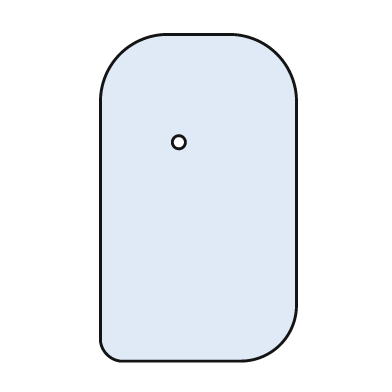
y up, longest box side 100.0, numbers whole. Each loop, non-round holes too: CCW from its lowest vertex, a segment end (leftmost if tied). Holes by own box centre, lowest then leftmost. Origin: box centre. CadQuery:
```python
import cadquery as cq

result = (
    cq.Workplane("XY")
    .moveTo(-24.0, -50.0)
    .lineTo(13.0, -50.0)
    .threePointArc((25.0, -45.0), (30.0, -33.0))
    .lineTo(30.0, 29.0)
    .threePointArc((24.0, 44.0), (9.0, 50.0))
    .lineTo(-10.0, 50.0)
    .threePointArc((-24.0, 44.0), (-30.0, 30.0))
    .lineTo(-30.0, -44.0)
    .threePointArc((-28.0, -48.0), (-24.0, -50.0))
    .close()
    .moveTo(-6.0, 17.0)
    .circle(2.0)
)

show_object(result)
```